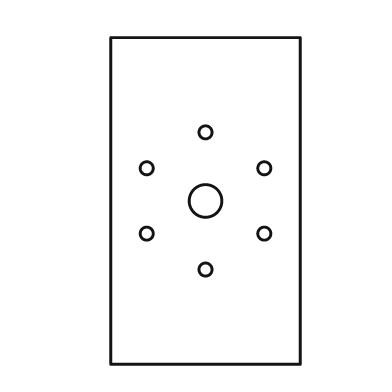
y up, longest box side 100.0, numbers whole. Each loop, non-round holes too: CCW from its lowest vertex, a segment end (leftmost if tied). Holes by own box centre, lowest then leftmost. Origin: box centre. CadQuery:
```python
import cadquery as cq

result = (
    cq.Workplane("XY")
    .moveTo(-29.0, -50.0)
    .lineTo(29.0, -50.0)
    .lineTo(29.0, 50.0)
    .lineTo(-29.0, 50.0)
    .close()
    .moveTo(0.0, -21.0)
    .circle(2.0)
    .moveTo(-18.0, -10.0)
    .circle(2.0)
    .moveTo(18.0, -10.0)
    .circle(2.0)
    .moveTo(0.0, 0.0)
    .circle(5.0)
    .moveTo(-18.0, 10.0)
    .circle(2.0)
    .moveTo(18.0, 10.0)
    .circle(2.0)
    .moveTo(0.0, 21.0)
    .circle(2.0)
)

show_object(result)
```